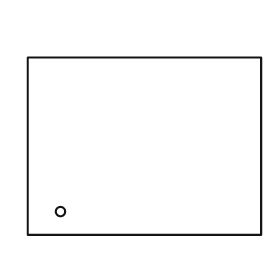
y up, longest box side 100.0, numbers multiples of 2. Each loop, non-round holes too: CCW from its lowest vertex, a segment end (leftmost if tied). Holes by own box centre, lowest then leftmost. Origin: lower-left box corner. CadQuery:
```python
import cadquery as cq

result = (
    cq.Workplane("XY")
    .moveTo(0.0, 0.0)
    .lineTo(100.0, 0.0)
    .lineTo(100.0, 76.0)
    .lineTo(0.0, 76.0)
    .close()
    .moveTo(14.0, 10.0)
    .circle(2.0)
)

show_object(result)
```